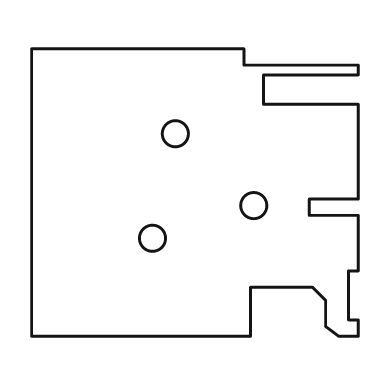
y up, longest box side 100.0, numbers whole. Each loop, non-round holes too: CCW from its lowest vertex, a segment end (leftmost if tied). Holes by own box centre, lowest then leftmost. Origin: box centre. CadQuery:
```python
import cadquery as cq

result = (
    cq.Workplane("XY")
    .moveTo(-50.0, -44.0)
    .lineTo(17.0, -44.0)
    .lineTo(17.0, -29.0)
    .lineTo(36.0, -29.0)
    .lineTo(40.0, -33.0)
    .lineTo(40.0, -41.0)
    .lineTo(44.0, -44.0)
    .lineTo(50.0, -44.0)
    .lineTo(50.0, -39.0)
    .lineTo(47.0, -39.0)
    .lineTo(47.0, -24.0)
    .lineTo(50.0, -24.0)
    .lineTo(50.0, -7.0)
    .lineTo(35.0, -7.0)
    .lineTo(35.0, -2.0)
    .lineTo(50.0, -2.0)
    .lineTo(50.0, 27.0)
    .lineTo(21.0, 27.0)
    .lineTo(21.0, 36.0)
    .lineTo(50.0, 36.0)
    .lineTo(50.0, 39.0)
    .lineTo(15.0, 39.0)
    .lineTo(15.0, 44.0)
    .lineTo(-50.0, 44.0)
    .close()
    .moveTo(-13.0, -14.0)
    .circle(4.0)
    .moveTo(18.0, -4.0)
    .circle(4.0)
    .moveTo(-6.0, 18.0)
    .circle(4.0)
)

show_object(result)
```